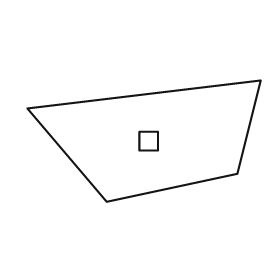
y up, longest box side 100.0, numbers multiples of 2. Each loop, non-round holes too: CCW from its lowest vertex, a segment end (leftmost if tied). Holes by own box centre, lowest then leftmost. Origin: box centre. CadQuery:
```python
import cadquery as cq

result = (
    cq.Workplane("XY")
    .moveTo(-16.0, -26.0)
    .lineTo(40.0, -14.0)
    .lineTo(50.0, 26.0)
    .lineTo(-50.0, 14.0)
    .close()
    .moveTo(-2.0, -4.0)
    .lineTo(6.0, -4.0)
    .lineTo(6.0, 4.0)
    .lineTo(-2.0, 4.0)
    .close()
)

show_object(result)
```